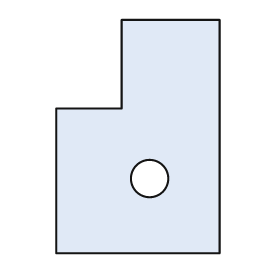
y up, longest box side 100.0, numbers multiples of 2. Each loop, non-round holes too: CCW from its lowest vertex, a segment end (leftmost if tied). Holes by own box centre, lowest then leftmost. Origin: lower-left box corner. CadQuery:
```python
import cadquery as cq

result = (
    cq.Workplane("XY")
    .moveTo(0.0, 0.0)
    .lineTo(70.0, 0.0)
    .lineTo(70.0, 100.0)
    .lineTo(28.0, 100.0)
    .lineTo(28.0, 62.0)
    .lineTo(0.0, 62.0)
    .close()
    .moveTo(40.0, 32.0)
    .circle(8.0)
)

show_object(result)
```